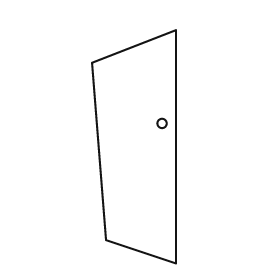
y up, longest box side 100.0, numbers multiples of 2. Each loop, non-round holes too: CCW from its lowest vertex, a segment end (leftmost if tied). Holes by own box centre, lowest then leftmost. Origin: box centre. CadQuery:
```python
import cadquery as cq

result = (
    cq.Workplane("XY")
    .moveTo(18.0, -50.0)
    .lineTo(18.0, 50.0)
    .lineTo(-18.0, 36.0)
    .lineTo(-12.0, -40.0)
    .close()
    .moveTo(12.0, 10.0)
    .circle(2.0)
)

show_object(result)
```